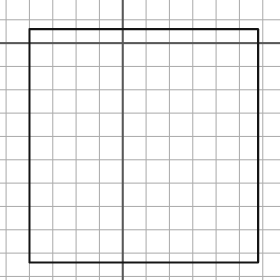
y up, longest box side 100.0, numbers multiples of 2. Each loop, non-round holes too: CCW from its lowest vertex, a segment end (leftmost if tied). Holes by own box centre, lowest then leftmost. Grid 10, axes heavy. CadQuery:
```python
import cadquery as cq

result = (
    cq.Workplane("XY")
    .moveTo(-40.0, -94.0)
    .lineTo(58.0, -94.0)
    .lineTo(58.0, 6.0)
    .lineTo(-40.0, 6.0)
    .close()
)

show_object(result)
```